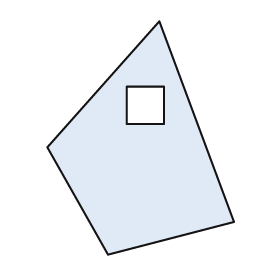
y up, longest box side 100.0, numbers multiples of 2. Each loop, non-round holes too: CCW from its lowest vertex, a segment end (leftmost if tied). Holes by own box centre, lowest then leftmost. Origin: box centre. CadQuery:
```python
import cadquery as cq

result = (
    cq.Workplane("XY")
    .moveTo(-14.0, -50.0)
    .lineTo(40.0, -36.0)
    .lineTo(8.0, 50.0)
    .lineTo(-40.0, -4.0)
    .close()
    .moveTo(-6.0, 6.0)
    .lineTo(10.0, 6.0)
    .lineTo(10.0, 22.0)
    .lineTo(-6.0, 22.0)
    .close()
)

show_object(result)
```